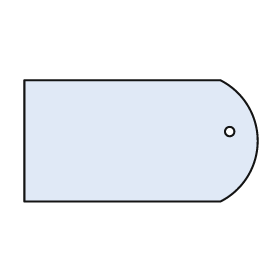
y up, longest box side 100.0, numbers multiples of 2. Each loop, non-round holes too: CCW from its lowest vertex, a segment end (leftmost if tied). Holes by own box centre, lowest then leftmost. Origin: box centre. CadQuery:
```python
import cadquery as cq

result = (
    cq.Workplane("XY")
    .moveTo(-50.0, -26.0)
    .lineTo(34.0, -26.0)
    .threePointArc((50.0, 0.0), (34.0, 26.0))
    .lineTo(-50.0, 26.0)
    .close()
    .moveTo(38.0, 4.0)
    .circle(2.0)
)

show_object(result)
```